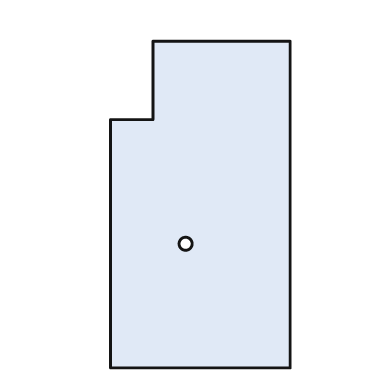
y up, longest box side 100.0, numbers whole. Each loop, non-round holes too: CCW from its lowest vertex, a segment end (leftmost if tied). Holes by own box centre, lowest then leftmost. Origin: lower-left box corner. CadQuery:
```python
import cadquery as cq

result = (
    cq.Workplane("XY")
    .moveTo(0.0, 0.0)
    .lineTo(55.0, 0.0)
    .lineTo(55.0, 100.0)
    .lineTo(13.0, 100.0)
    .lineTo(13.0, 76.0)
    .lineTo(0.0, 76.0)
    .close()
    .moveTo(23.0, 38.0)
    .circle(2.0)
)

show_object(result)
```